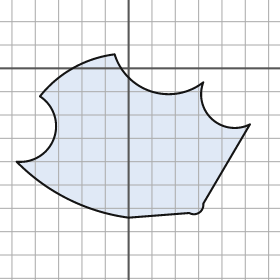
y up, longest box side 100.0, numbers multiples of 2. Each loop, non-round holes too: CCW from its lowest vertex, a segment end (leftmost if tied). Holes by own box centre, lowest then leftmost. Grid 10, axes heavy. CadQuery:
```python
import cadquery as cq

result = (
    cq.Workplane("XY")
    .moveTo(0.0, -64.0)
    .lineTo(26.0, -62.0)
    .threePointArc((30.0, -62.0), (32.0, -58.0))
    .lineTo(52.0, -24.0)
    .threePointArc((36.0, -22.0), (32.0, -6.0))
    .threePointArc((10.0, -10.0), (-6.0, 6.0))
    .threePointArc((-24.0, 0.0), (-38.0, -12.0))
    .threePointArc((-32.0, -30.0), (-48.0, -40.0))
    .threePointArc((-26.0, -56.0), (0.0, -64.0))
    .close()
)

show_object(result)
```